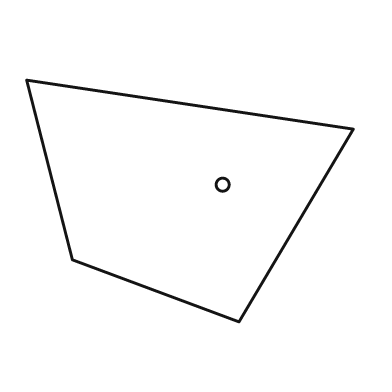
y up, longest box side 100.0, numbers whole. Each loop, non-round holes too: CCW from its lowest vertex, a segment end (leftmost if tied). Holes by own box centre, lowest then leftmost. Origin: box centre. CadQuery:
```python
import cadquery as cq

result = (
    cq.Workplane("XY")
    .moveTo(15.0, -37.0)
    .lineTo(50.0, 22.0)
    .lineTo(-50.0, 37.0)
    .lineTo(-36.0, -18.0)
    .close()
    .moveTo(10.0, 5.0)
    .circle(2.0)
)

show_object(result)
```